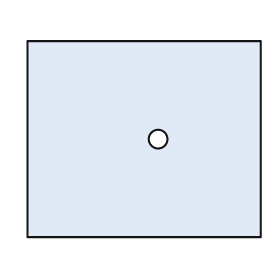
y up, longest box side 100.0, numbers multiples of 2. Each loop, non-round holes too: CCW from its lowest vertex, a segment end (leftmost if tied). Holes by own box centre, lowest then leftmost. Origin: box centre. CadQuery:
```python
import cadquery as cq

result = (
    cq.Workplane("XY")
    .moveTo(-50.0, -42.0)
    .lineTo(50.0, -42.0)
    .lineTo(50.0, 42.0)
    .lineTo(-50.0, 42.0)
    .close()
    .moveTo(6.0, 0.0)
    .circle(4.0)
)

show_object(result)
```